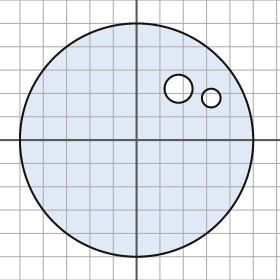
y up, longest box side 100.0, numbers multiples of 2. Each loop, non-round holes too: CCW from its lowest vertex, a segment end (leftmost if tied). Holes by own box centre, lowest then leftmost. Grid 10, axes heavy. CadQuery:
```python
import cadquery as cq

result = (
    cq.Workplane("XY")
    .moveTo(0.0, 0.0)
    .circle(50.0)
    .moveTo(32.0, 18.0)
    .circle(4.0)
    .moveTo(18.0, 22.0)
    .circle(6.0)
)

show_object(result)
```